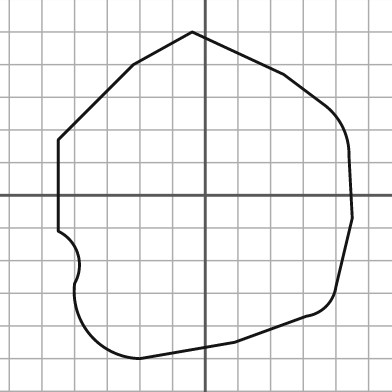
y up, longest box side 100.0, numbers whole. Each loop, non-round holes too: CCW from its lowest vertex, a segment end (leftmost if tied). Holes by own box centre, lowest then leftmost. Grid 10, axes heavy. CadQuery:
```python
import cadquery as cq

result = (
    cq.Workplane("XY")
    .moveTo(-20.0, -50.0)
    .lineTo(9.0, -45.0)
    .lineTo(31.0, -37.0)
    .threePointArc((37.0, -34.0), (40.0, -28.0))
    .lineTo(45.0, -7.0)
    .lineTo(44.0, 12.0)
    .threePointArc((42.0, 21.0), (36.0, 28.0))
    .lineTo(24.0, 37.0)
    .lineTo(-4.0, 50.0)
    .lineTo(-22.0, 40.0)
    .lineTo(-45.0, 17.0)
    .lineTo(-45.0, -11.0)
    .threePointArc((-39.0, -18.0), (-40.0, -27.0))
    .threePointArc((-35.0, -43.0), (-20.0, -50.0))
    .close()
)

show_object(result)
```